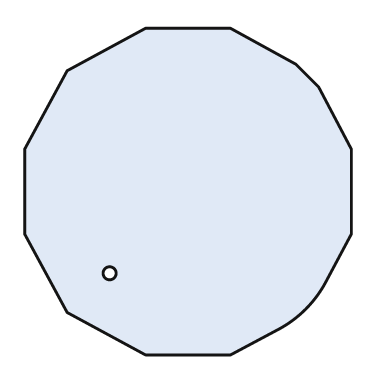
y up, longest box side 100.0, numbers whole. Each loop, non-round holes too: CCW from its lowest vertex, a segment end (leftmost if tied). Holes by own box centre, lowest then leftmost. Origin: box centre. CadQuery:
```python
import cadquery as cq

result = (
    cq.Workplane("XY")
    .moveTo(-13.0, -50.0)
    .lineTo(13.0, -50.0)
    .lineTo(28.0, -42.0)
    .threePointArc((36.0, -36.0), (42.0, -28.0))
    .lineTo(50.0, -13.0)
    .lineTo(50.0, 13.0)
    .lineTo(40.0, 32.0)
    .lineTo(33.0, 39.0)
    .lineTo(13.0, 50.0)
    .lineTo(-13.0, 50.0)
    .lineTo(-37.0, 37.0)
    .lineTo(-50.0, 13.0)
    .lineTo(-50.0, -13.0)
    .lineTo(-37.0, -37.0)
    .close()
    .moveTo(-24.0, -25.0)
    .circle(2.0)
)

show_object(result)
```